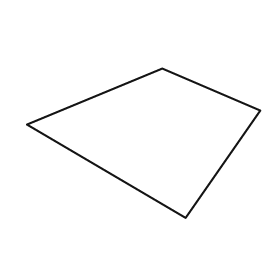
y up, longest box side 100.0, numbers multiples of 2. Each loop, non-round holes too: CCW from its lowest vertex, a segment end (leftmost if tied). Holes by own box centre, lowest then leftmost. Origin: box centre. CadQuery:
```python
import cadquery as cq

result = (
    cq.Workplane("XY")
    .moveTo(18.0, -32.0)
    .lineTo(50.0, 14.0)
    .lineTo(8.0, 32.0)
    .lineTo(-50.0, 8.0)
    .close()
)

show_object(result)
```